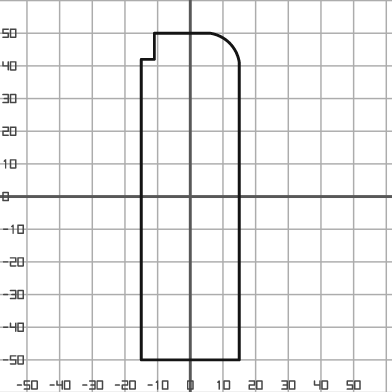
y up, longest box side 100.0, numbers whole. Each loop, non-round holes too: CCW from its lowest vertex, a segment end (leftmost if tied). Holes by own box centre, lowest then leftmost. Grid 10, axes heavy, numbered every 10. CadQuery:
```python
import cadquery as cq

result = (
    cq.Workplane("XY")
    .moveTo(-15.0, -50.0)
    .lineTo(15.0, -50.0)
    .lineTo(15.0, 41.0)
    .threePointArc((12.0, 47.0), (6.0, 50.0))
    .lineTo(-11.0, 50.0)
    .lineTo(-11.0, 42.0)
    .lineTo(-15.0, 42.0)
    .close()
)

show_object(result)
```